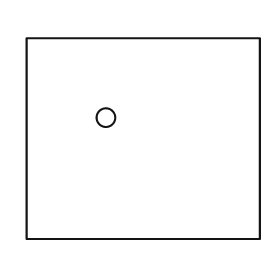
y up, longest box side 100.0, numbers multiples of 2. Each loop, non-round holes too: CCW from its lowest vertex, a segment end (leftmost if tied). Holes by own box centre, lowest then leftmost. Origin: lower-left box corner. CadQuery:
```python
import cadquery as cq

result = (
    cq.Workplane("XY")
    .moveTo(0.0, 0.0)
    .lineTo(100.0, 0.0)
    .lineTo(100.0, 86.0)
    .lineTo(0.0, 86.0)
    .close()
    .moveTo(34.0, 52.0)
    .circle(4.0)
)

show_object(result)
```